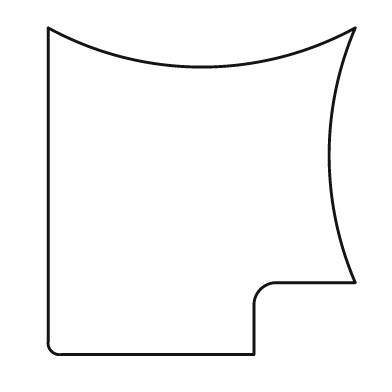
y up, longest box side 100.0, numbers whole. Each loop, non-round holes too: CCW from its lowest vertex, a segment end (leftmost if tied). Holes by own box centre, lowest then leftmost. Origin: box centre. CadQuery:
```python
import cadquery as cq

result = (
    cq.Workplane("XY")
    .moveTo(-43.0, -50.0)
    .lineTo(16.0, -50.0)
    .lineTo(16.0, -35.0)
    .threePointArc((18.0, -30.0), (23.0, -28.0))
    .lineTo(47.0, -28.0)
    .threePointArc((39.0, 11.0), (47.0, 50.0))
    .threePointArc((0.0, 38.0), (-47.0, 50.0))
    .lineTo(-47.0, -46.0)
    .threePointArc((-46.0, -49.0), (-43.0, -50.0))
    .close()
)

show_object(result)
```